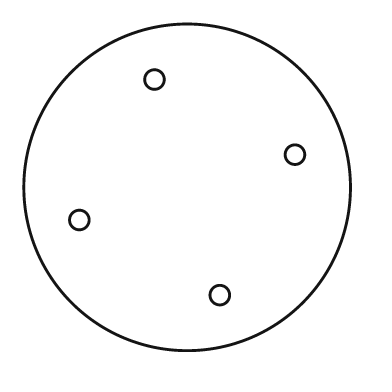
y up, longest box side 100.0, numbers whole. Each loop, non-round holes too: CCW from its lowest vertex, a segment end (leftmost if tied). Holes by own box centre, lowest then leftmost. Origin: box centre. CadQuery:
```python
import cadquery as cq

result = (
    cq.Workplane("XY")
    .moveTo(0.0, 0.0)
    .circle(50.0)
    .moveTo(10.0, -33.0)
    .circle(3.0)
    .moveTo(-33.0, -10.0)
    .circle(3.0)
    .moveTo(33.0, 10.0)
    .circle(3.0)
    .moveTo(-10.0, 33.0)
    .circle(3.0)
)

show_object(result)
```